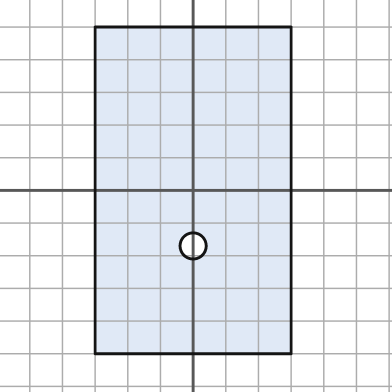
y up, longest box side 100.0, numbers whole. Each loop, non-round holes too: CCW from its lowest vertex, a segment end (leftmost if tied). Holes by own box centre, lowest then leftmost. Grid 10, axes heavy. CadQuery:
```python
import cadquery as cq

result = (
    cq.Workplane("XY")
    .moveTo(-30.0, -50.0)
    .lineTo(30.0, -50.0)
    .lineTo(30.0, 50.0)
    .lineTo(-30.0, 50.0)
    .close()
    .moveTo(0.0, -17.0)
    .circle(4.0)
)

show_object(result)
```